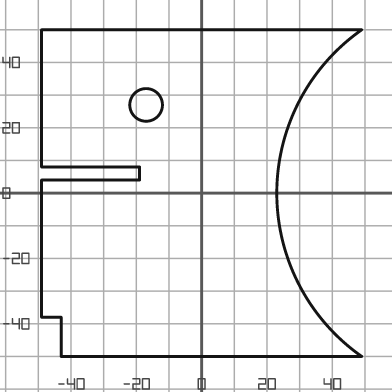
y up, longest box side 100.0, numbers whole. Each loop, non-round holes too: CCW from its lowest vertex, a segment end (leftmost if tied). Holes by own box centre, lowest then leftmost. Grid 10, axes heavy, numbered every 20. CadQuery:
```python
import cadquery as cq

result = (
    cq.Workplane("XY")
    .moveTo(-43.0, -50.0)
    .lineTo(49.0, -50.0)
    .threePointArc((23.0, 0.0), (49.0, 50.0))
    .lineTo(-49.0, 50.0)
    .lineTo(-49.0, 8.0)
    .lineTo(-19.0, 8.0)
    .lineTo(-19.0, 4.0)
    .lineTo(-49.0, 4.0)
    .lineTo(-49.0, -38.0)
    .lineTo(-43.0, -38.0)
    .close()
    .moveTo(-17.0, 27.0)
    .circle(5.0)
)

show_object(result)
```